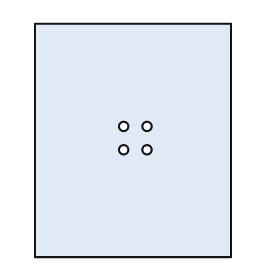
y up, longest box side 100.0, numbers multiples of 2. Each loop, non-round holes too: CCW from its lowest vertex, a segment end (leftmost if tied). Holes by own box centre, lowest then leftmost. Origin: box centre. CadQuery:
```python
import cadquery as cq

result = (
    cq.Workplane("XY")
    .moveTo(-42.0, -50.0)
    .lineTo(42.0, -50.0)
    .lineTo(42.0, 50.0)
    .lineTo(-42.0, 50.0)
    .close()
    .moveTo(-4.0, -4.0)
    .circle(2.0)
    .moveTo(6.0, -4.0)
    .circle(2.0)
    .moveTo(-4.0, 6.0)
    .circle(2.0)
    .moveTo(6.0, 6.0)
    .circle(2.0)
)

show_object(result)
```